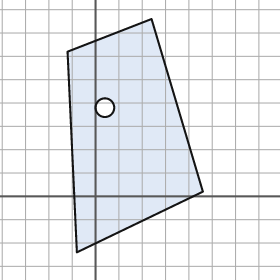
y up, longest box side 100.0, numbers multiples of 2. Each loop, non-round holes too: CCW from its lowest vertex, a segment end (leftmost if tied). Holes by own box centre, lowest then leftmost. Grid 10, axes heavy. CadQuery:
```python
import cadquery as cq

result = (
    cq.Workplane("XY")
    .moveTo(-8.0, -24.0)
    .lineTo(46.0, 2.0)
    .lineTo(24.0, 76.0)
    .lineTo(-12.0, 62.0)
    .close()
    .moveTo(4.0, 38.0)
    .circle(4.0)
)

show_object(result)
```